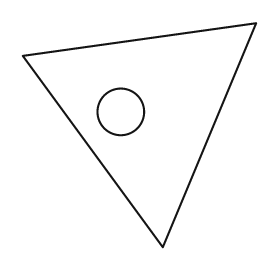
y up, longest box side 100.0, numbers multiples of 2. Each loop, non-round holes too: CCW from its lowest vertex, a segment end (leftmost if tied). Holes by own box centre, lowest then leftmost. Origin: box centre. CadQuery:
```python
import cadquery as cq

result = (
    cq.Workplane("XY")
    .moveTo(10.0, -48.0)
    .lineTo(50.0, 48.0)
    .lineTo(-50.0, 34.0)
    .close()
    .moveTo(-8.0, 10.0)
    .circle(10.0)
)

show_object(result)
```